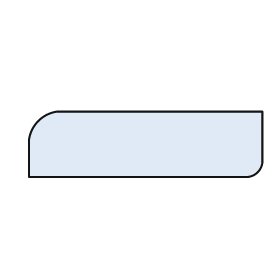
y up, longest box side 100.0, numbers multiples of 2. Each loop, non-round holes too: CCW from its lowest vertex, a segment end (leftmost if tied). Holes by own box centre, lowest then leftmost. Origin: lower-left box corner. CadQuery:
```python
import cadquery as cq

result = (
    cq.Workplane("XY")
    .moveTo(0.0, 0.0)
    .lineTo(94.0, 0.0)
    .threePointArc((98.0, 2.0), (100.0, 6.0))
    .lineTo(100.0, 28.0)
    .lineTo(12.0, 28.0)
    .threePointArc((4.0, 24.0), (0.0, 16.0))
    .close()
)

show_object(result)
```